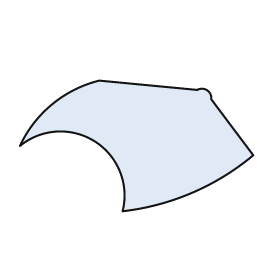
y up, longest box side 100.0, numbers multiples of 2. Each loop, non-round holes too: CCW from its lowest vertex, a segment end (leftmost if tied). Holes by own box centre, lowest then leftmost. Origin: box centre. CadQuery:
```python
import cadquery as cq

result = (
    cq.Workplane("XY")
    .moveTo(-6.0, -28.0)
    .threePointArc((24.0, -20.0), (50.0, -4.0))
    .lineTo(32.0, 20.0)
    .threePointArc((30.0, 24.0), (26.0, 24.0))
    .lineTo(-16.0, 28.0)
    .threePointArc((-36.0, 18.0), (-50.0, 0.0))
    .threePointArc((-18.0, 2.0), (-6.0, -28.0))
    .close()
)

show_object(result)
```